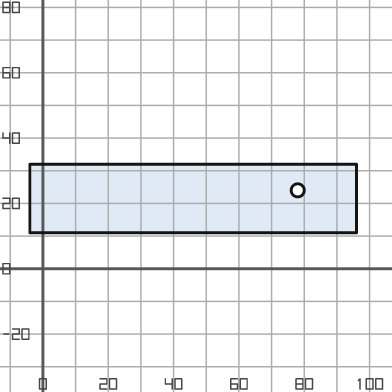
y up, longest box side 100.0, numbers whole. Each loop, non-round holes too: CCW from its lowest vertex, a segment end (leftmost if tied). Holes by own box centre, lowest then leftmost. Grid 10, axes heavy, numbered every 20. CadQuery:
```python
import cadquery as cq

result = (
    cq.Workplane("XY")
    .moveTo(-4.0, 11.0)
    .lineTo(96.0, 11.0)
    .lineTo(96.0, 32.0)
    .lineTo(-4.0, 32.0)
    .close()
    .moveTo(78.0, 24.0)
    .circle(2.0)
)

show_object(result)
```